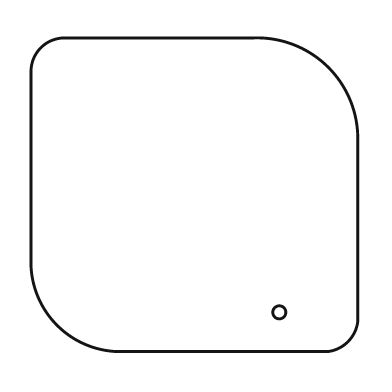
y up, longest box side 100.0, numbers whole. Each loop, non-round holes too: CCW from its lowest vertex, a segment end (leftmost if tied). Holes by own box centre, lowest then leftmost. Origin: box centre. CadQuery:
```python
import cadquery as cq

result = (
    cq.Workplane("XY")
    .moveTo(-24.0, -48.0)
    .lineTo(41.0, -48.0)
    .threePointArc((47.0, -45.0), (50.0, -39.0))
    .lineTo(50.0, 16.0)
    .threePointArc((41.0, 39.0), (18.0, 48.0))
    .lineTo(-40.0, 48.0)
    .threePointArc((-47.0, 45.0), (-50.0, 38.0))
    .lineTo(-50.0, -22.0)
    .threePointArc((-42.0, -40.0), (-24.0, -48.0))
    .close()
    .moveTo(26.0, -36.0)
    .circle(2.0)
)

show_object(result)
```